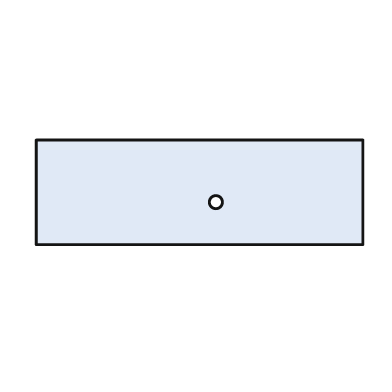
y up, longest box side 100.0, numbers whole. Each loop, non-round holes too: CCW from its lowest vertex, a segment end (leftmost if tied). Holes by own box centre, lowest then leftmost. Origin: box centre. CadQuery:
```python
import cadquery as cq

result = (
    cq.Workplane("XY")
    .moveTo(-50.0, -16.0)
    .lineTo(50.0, -16.0)
    .lineTo(50.0, 16.0)
    .lineTo(-50.0, 16.0)
    .close()
    .moveTo(5.0, -3.0)
    .circle(2.0)
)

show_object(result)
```